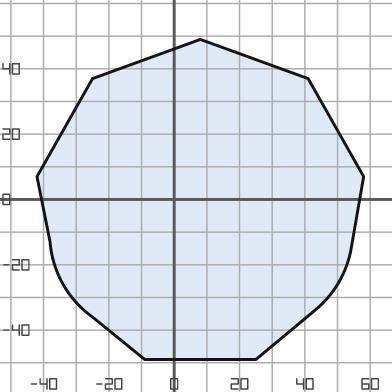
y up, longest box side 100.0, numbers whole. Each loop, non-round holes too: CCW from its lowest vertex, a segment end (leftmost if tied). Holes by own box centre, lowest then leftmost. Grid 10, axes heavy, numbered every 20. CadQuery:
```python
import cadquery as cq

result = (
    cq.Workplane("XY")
    .moveTo(-9.0, -49.0)
    .lineTo(25.0, -49.0)
    .lineTo(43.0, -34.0)
    .threePointArc((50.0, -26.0), (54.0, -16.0))
    .lineTo(58.0, 7.0)
    .lineTo(41.0, 37.0)
    .lineTo(8.0, 49.0)
    .lineTo(-25.0, 37.0)
    .lineTo(-42.0, 7.0)
    .lineTo(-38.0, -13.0)
    .threePointArc((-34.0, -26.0), (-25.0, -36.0))
    .close()
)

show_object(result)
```